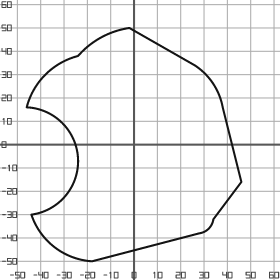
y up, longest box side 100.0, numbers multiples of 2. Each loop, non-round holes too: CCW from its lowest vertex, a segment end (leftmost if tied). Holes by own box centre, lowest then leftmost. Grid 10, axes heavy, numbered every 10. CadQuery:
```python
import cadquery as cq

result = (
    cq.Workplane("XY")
    .moveTo(-18.0, -50.0)
    .lineTo(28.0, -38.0)
    .threePointArc((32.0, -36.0), (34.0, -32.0))
    .lineTo(46.0, -16.0)
    .lineTo(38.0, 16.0)
    .threePointArc((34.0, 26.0), (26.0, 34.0))
    .lineTo(-2.0, 50.0)
    .threePointArc((-14.0, 46.0), (-24.0, 38.0))
    .threePointArc((-38.0, 30.0), (-46.0, 16.0))
    .threePointArc((-24.0, -6.0), (-44.0, -30.0))
    .threePointArc((-34.0, -44.0), (-18.0, -50.0))
    .close()
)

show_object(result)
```